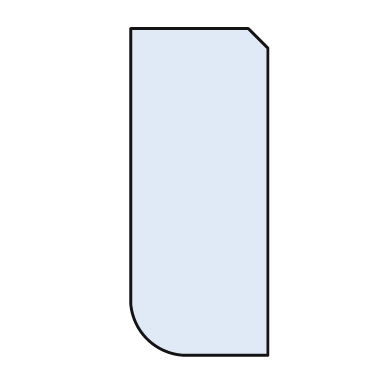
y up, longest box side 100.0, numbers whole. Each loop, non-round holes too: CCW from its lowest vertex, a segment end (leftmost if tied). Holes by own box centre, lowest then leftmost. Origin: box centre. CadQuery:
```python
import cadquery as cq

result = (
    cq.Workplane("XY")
    .moveTo(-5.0, -50.0)
    .lineTo(21.0, -50.0)
    .lineTo(21.0, 44.0)
    .lineTo(15.0, 50.0)
    .lineTo(-21.0, 50.0)
    .lineTo(-21.0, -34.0)
    .threePointArc((-16.0, -45.0), (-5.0, -50.0))
    .close()
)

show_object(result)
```